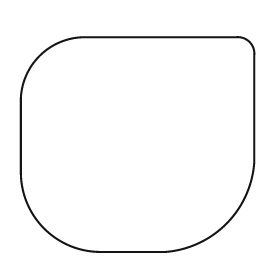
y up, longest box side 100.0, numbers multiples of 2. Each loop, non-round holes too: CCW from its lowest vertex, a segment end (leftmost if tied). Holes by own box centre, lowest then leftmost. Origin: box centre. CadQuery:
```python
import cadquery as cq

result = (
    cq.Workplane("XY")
    .moveTo(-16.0, -46.0)
    .lineTo(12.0, -46.0)
    .threePointArc((38.0, -34.0), (50.0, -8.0))
    .lineTo(50.0, 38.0)
    .threePointArc((48.0, 44.0), (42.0, 46.0))
    .lineTo(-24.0, 46.0)
    .threePointArc((-42.0, 38.0), (-50.0, 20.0))
    .lineTo(-50.0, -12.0)
    .threePointArc((-40.0, -36.0), (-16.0, -46.0))
    .close()
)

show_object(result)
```